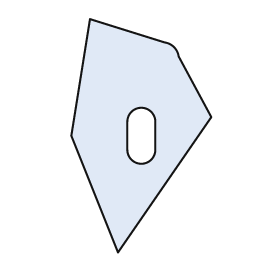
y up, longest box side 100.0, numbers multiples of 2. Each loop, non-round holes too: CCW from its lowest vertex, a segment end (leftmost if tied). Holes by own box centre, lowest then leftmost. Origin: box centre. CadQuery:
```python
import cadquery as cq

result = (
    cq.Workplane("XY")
    .moveTo(-10.0, -50.0)
    .lineTo(30.0, 8.0)
    .lineTo(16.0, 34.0)
    .threePointArc((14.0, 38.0), (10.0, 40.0))
    .lineTo(-22.0, 50.0)
    .lineTo(-30.0, 0.0)
    .close()
    .moveTo(-6.0, -6.0)
    .threePointArc((0.0, -12.0), (6.0, -6.0))
    .lineTo(6.0, 6.0)
    .threePointArc((0.0, 12.0), (-6.0, 6.0))
    .close()
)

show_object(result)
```